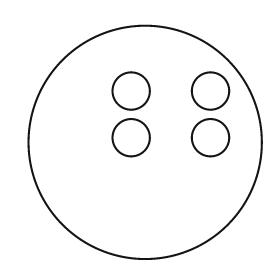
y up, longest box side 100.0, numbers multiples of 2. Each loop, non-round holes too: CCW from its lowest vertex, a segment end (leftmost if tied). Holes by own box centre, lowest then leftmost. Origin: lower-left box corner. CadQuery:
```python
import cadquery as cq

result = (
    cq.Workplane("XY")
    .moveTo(50.0, 50.0)
    .circle(50.0)
    .moveTo(44.0, 52.0)
    .circle(8.0)
    .moveTo(78.0, 52.0)
    .circle(8.0)
    .moveTo(44.0, 72.0)
    .circle(8.0)
    .moveTo(78.0, 72.0)
    .circle(8.0)
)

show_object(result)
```